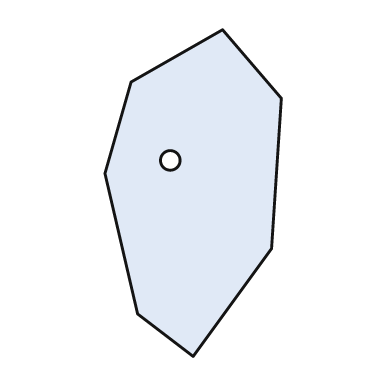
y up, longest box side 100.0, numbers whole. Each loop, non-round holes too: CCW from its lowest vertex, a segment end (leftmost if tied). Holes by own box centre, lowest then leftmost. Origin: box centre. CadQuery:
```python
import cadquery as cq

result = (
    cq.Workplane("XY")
    .moveTo(0.0, -50.0)
    .lineTo(24.0, -17.0)
    .lineTo(27.0, 29.0)
    .lineTo(9.0, 50.0)
    .lineTo(-19.0, 34.0)
    .lineTo(-27.0, 6.0)
    .lineTo(-17.0, -37.0)
    .close()
    .moveTo(-7.0, 10.0)
    .circle(3.0)
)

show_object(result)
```